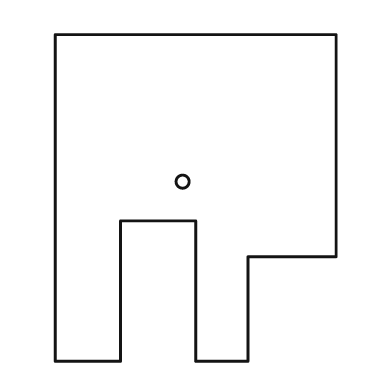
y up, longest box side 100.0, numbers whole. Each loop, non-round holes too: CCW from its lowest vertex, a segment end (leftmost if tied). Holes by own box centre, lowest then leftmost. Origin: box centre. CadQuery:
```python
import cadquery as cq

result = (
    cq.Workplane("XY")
    .moveTo(-43.0, -50.0)
    .lineTo(-23.0, -50.0)
    .lineTo(-23.0, -7.0)
    .lineTo(0.0, -7.0)
    .lineTo(0.0, -50.0)
    .lineTo(16.0, -50.0)
    .lineTo(16.0, -18.0)
    .lineTo(43.0, -18.0)
    .lineTo(43.0, 50.0)
    .lineTo(-43.0, 50.0)
    .close()
    .moveTo(-4.0, 5.0)
    .circle(2.0)
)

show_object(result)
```